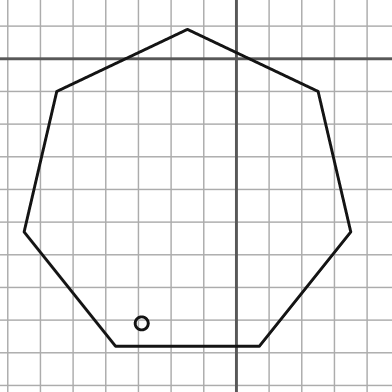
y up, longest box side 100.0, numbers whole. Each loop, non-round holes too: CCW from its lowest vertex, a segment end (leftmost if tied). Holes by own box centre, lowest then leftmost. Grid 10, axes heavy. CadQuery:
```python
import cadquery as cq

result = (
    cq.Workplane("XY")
    .moveTo(-37.0, -88.0)
    .lineTo(7.0, -88.0)
    .lineTo(35.0, -53.0)
    .lineTo(25.0, -10.0)
    .lineTo(-15.0, 9.0)
    .lineTo(-55.0, -10.0)
    .lineTo(-65.0, -53.0)
    .close()
    .moveTo(-29.0, -81.0)
    .circle(2.0)
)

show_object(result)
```